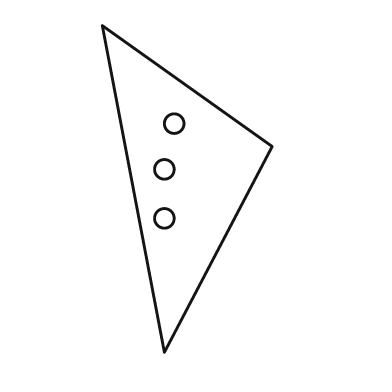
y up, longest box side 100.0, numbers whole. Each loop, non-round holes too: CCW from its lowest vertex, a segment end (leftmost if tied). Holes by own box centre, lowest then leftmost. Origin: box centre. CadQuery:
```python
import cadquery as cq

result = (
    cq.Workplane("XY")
    .moveTo(-7.0, -50.0)
    .lineTo(26.0, 13.0)
    .lineTo(-26.0, 50.0)
    .close()
    .moveTo(-7.0, -9.0)
    .circle(3.0)
    .moveTo(-7.0, 6.0)
    .circle(3.0)
    .moveTo(-4.0, 20.0)
    .circle(3.0)
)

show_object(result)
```